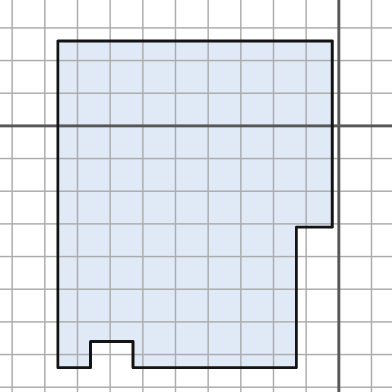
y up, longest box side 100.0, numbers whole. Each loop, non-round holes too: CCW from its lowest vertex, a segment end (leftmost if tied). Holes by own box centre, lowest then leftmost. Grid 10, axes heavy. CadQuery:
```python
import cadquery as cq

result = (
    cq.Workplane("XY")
    .moveTo(-86.0, -74.0)
    .lineTo(-76.0, -74.0)
    .lineTo(-76.0, -66.0)
    .lineTo(-63.0, -66.0)
    .lineTo(-63.0, -74.0)
    .lineTo(-13.0, -74.0)
    .lineTo(-13.0, -31.0)
    .lineTo(-2.0, -31.0)
    .lineTo(-2.0, 26.0)
    .lineTo(-86.0, 26.0)
    .close()
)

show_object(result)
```